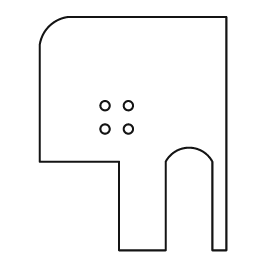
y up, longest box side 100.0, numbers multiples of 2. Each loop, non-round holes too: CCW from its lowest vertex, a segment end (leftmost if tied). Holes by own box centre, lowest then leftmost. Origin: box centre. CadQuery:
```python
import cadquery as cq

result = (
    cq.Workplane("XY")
    .moveTo(-6.0, -50.0)
    .lineTo(14.0, -50.0)
    .lineTo(14.0, -12.0)
    .threePointArc((24.0, -6.0), (34.0, -12.0))
    .lineTo(34.0, -50.0)
    .lineTo(40.0, -50.0)
    .lineTo(40.0, 50.0)
    .lineTo(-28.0, 50.0)
    .threePointArc((-36.0, 46.0), (-40.0, 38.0))
    .lineTo(-40.0, -12.0)
    .lineTo(-6.0, -12.0)
    .close()
    .moveTo(-12.0, 2.0)
    .circle(2.0)
    .moveTo(-2.0, 2.0)
    .circle(2.0)
    .moveTo(-12.0, 12.0)
    .circle(2.0)
    .moveTo(-2.0, 12.0)
    .circle(2.0)
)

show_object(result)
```